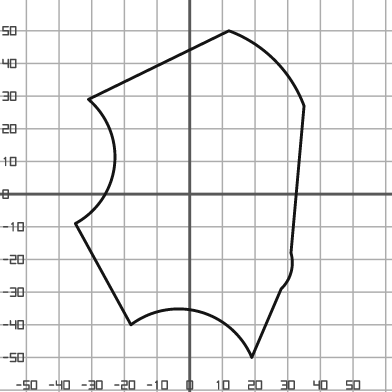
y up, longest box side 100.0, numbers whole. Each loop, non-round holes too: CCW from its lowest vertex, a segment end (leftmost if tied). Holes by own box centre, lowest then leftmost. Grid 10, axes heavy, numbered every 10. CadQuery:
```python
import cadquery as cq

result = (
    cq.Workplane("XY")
    .moveTo(19.0, -50.0)
    .lineTo(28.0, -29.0)
    .threePointArc((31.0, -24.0), (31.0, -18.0))
    .lineTo(35.0, 27.0)
    .threePointArc((26.0, 41.0), (12.0, 50.0))
    .lineTo(-31.0, 29.0)
    .threePointArc((-23.0, 9.0), (-35.0, -9.0))
    .lineTo(-18.0, -40.0)
    .threePointArc((3.0, -36.0), (19.0, -50.0))
    .close()
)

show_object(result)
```